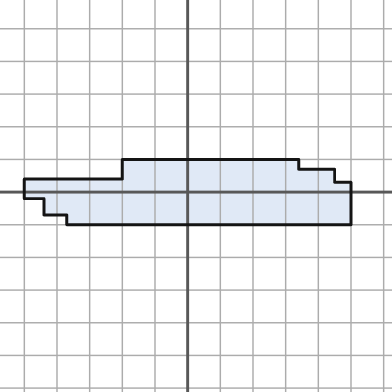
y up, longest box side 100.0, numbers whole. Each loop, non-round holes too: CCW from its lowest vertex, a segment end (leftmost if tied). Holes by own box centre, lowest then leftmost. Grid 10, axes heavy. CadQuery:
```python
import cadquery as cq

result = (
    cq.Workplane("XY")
    .moveTo(-37.0, -10.0)
    .lineTo(50.0, -10.0)
    .lineTo(50.0, 3.0)
    .lineTo(45.0, 3.0)
    .lineTo(45.0, 7.0)
    .lineTo(34.0, 7.0)
    .lineTo(34.0, 10.0)
    .lineTo(-20.0, 10.0)
    .lineTo(-20.0, 4.0)
    .lineTo(-50.0, 4.0)
    .lineTo(-50.0, -2.0)
    .lineTo(-44.0, -2.0)
    .lineTo(-44.0, -7.0)
    .lineTo(-37.0, -7.0)
    .close()
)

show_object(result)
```